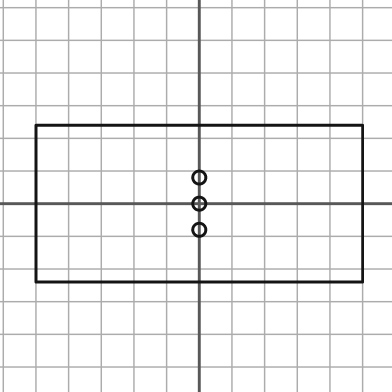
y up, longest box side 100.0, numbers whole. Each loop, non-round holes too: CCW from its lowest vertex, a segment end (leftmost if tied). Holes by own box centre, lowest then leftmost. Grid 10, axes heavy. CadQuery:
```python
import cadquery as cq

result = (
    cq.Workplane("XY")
    .moveTo(-50.0, -24.0)
    .lineTo(50.0, -24.0)
    .lineTo(50.0, 24.0)
    .lineTo(-50.0, 24.0)
    .close()
    .moveTo(0.0, -8.0)
    .circle(2.0)
    .moveTo(0.0, 0.0)
    .circle(2.0)
    .moveTo(0.0, 8.0)
    .circle(2.0)
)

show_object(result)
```